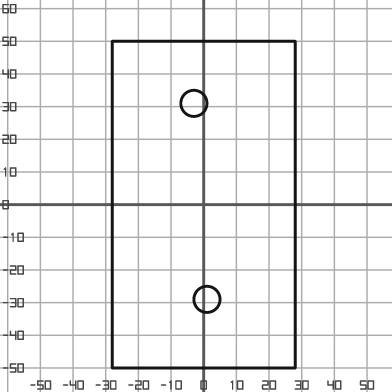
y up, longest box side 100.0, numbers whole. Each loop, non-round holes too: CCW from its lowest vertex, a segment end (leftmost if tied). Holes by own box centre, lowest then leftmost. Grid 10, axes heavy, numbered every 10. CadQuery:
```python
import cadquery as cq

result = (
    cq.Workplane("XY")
    .moveTo(-28.0, -50.0)
    .lineTo(28.0, -50.0)
    .lineTo(28.0, 50.0)
    .lineTo(-28.0, 50.0)
    .close()
    .moveTo(1.0, -29.0)
    .circle(4.0)
    .moveTo(-3.0, 31.0)
    .circle(4.0)
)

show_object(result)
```